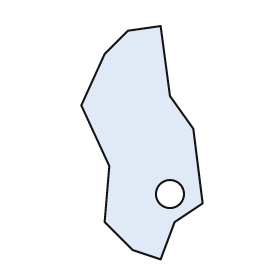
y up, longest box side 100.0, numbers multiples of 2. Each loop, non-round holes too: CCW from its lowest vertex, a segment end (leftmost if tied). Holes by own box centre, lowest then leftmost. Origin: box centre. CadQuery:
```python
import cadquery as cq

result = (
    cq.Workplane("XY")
    .moveTo(8.0, -50.0)
    .lineTo(14.0, -34.0)
    .lineTo(26.0, -26.0)
    .lineTo(22.0, 6.0)
    .lineTo(12.0, 20.0)
    .lineTo(8.0, 50.0)
    .lineTo(-6.0, 48.0)
    .lineTo(-16.0, 38.0)
    .lineTo(-26.0, 16.0)
    .lineTo(-14.0, -10.0)
    .lineTo(-16.0, -34.0)
    .lineTo(-4.0, -46.0)
    .close()
    .moveTo(12.0, -22.0)
    .circle(6.0)
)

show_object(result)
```